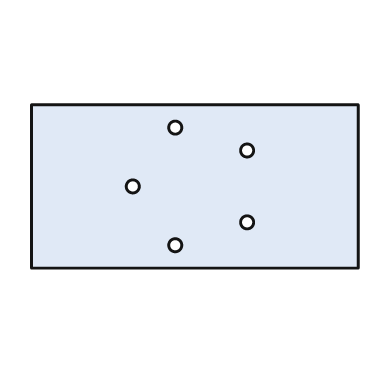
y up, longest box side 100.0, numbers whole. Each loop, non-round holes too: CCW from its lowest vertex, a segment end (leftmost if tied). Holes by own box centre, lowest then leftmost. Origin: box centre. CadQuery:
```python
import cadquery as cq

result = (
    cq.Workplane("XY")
    .moveTo(-50.0, -25.0)
    .lineTo(50.0, -25.0)
    .lineTo(50.0, 25.0)
    .lineTo(-50.0, 25.0)
    .close()
    .moveTo(-6.0, -18.0)
    .circle(2.0)
    .moveTo(16.0, -11.0)
    .circle(2.0)
    .moveTo(-19.0, 0.0)
    .circle(2.0)
    .moveTo(16.0, 11.0)
    .circle(2.0)
    .moveTo(-6.0, 18.0)
    .circle(2.0)
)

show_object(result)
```